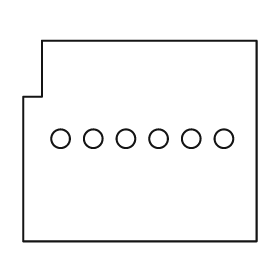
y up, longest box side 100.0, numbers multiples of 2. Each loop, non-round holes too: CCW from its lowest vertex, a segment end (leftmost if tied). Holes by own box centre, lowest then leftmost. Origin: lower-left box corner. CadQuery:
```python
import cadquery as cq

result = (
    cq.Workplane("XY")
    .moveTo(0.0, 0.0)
    .lineTo(100.0, 0.0)
    .lineTo(100.0, 86.0)
    .lineTo(8.0, 86.0)
    .lineTo(8.0, 62.0)
    .lineTo(0.0, 62.0)
    .close()
    .moveTo(16.0, 44.0)
    .circle(4.0)
    .moveTo(30.0, 44.0)
    .circle(4.0)
    .moveTo(44.0, 44.0)
    .circle(4.0)
    .moveTo(58.0, 44.0)
    .circle(4.0)
    .moveTo(72.0, 44.0)
    .circle(4.0)
    .moveTo(86.0, 44.0)
    .circle(4.0)
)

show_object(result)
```